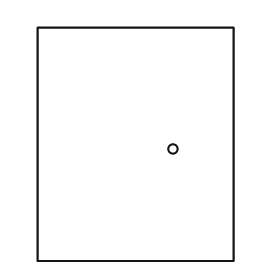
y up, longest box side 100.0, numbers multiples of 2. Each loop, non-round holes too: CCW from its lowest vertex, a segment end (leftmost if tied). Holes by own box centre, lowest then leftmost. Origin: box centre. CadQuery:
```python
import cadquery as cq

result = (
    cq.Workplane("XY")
    .moveTo(-42.0, -50.0)
    .lineTo(42.0, -50.0)
    .lineTo(42.0, 50.0)
    .lineTo(-42.0, 50.0)
    .close()
    .moveTo(16.0, -2.0)
    .circle(2.0)
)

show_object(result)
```